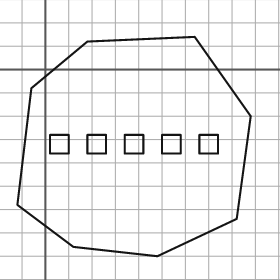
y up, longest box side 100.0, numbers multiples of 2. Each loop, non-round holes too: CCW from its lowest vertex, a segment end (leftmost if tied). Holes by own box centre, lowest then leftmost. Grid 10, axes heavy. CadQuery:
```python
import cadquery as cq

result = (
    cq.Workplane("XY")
    .moveTo(48.0, -80.0)
    .lineTo(82.0, -64.0)
    .lineTo(88.0, -20.0)
    .lineTo(64.0, 14.0)
    .lineTo(18.0, 12.0)
    .lineTo(-6.0, -8.0)
    .lineTo(-12.0, -58.0)
    .lineTo(12.0, -76.0)
    .close()
    .moveTo(2.0, -36.0)
    .lineTo(10.0, -36.0)
    .lineTo(10.0, -28.0)
    .lineTo(2.0, -28.0)
    .close()
    .moveTo(18.0, -36.0)
    .lineTo(26.0, -36.0)
    .lineTo(26.0, -28.0)
    .lineTo(18.0, -28.0)
    .close()
    .moveTo(34.0, -36.0)
    .lineTo(42.0, -36.0)
    .lineTo(42.0, -28.0)
    .lineTo(34.0, -28.0)
    .close()
    .moveTo(50.0, -36.0)
    .lineTo(58.0, -36.0)
    .lineTo(58.0, -28.0)
    .lineTo(50.0, -28.0)
    .close()
    .moveTo(66.0, -36.0)
    .lineTo(74.0, -36.0)
    .lineTo(74.0, -28.0)
    .lineTo(66.0, -28.0)
    .close()
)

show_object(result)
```